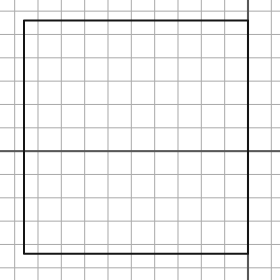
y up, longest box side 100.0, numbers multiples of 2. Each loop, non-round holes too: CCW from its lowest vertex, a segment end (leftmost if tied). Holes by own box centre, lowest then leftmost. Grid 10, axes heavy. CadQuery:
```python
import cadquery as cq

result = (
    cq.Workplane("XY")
    .moveTo(-96.0, -44.0)
    .lineTo(0.0, -44.0)
    .lineTo(0.0, 56.0)
    .lineTo(-96.0, 56.0)
    .close()
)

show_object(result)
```